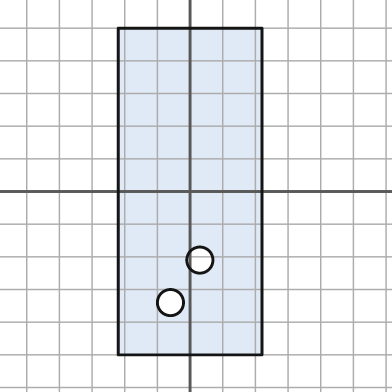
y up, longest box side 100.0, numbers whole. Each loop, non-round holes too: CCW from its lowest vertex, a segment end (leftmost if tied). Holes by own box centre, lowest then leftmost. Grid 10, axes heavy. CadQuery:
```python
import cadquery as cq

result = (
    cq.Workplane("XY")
    .moveTo(-22.0, -50.0)
    .lineTo(22.0, -50.0)
    .lineTo(22.0, 50.0)
    .lineTo(-22.0, 50.0)
    .close()
    .moveTo(-6.0, -34.0)
    .circle(4.0)
    .moveTo(3.0, -21.0)
    .circle(4.0)
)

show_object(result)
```